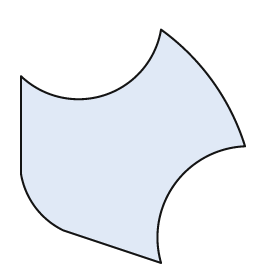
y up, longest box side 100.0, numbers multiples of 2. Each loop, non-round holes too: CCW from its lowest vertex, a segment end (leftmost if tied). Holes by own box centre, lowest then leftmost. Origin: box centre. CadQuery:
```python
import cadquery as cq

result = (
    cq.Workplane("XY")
    .moveTo(12.0, -50.0)
    .threePointArc((18.0, -16.0), (48.0, 0.0))
    .threePointArc((34.0, 28.0), (12.0, 50.0))
    .threePointArc((-12.0, 22.0), (-48.0, 30.0))
    .lineTo(-48.0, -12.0)
    .threePointArc((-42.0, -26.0), (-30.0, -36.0))
    .close()
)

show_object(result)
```